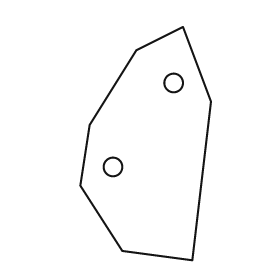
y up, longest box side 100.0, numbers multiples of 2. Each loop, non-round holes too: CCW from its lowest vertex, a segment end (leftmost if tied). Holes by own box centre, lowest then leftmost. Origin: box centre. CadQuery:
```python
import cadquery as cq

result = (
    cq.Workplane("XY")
    .moveTo(20.0, -50.0)
    .lineTo(28.0, 18.0)
    .lineTo(16.0, 50.0)
    .lineTo(-4.0, 40.0)
    .lineTo(-24.0, 8.0)
    .lineTo(-28.0, -18.0)
    .lineTo(-10.0, -46.0)
    .close()
    .moveTo(-14.0, -10.0)
    .circle(4.0)
    .moveTo(12.0, 26.0)
    .circle(4.0)
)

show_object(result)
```